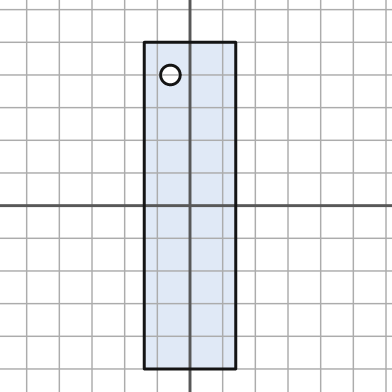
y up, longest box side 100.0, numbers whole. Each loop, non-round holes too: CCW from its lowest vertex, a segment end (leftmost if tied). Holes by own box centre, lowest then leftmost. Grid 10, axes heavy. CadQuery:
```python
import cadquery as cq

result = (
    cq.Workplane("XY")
    .moveTo(-14.0, -50.0)
    .lineTo(14.0, -50.0)
    .lineTo(14.0, 50.0)
    .lineTo(-14.0, 50.0)
    .close()
    .moveTo(-6.0, 40.0)
    .circle(3.0)
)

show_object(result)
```